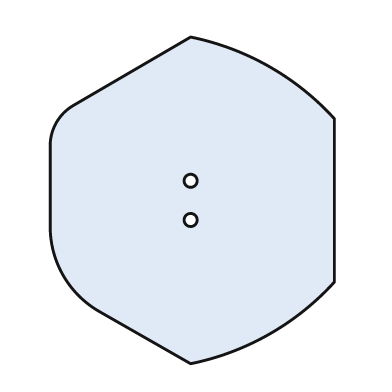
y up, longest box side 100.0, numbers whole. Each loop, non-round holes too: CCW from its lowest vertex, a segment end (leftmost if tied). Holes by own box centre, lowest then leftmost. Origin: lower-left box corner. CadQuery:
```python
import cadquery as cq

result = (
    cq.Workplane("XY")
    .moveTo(43.0, 0.0)
    .threePointArc((67.0, 9.0), (87.0, 25.0))
    .lineTo(87.0, 75.0)
    .threePointArc((67.0, 91.0), (43.0, 100.0))
    .lineTo(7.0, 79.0)
    .threePointArc((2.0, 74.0), (0.0, 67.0))
    .lineTo(0.0, 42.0)
    .threePointArc((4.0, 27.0), (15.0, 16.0))
    .close()
    .moveTo(43.0, 44.0)
    .circle(2.0)
    .moveTo(43.0, 56.0)
    .circle(2.0)
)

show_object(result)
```